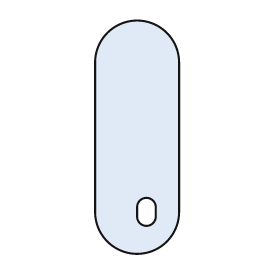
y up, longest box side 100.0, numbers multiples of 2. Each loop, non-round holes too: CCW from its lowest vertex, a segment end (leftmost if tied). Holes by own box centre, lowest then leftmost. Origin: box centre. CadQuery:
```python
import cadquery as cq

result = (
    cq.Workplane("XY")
    .moveTo(-18.0, -32.0)
    .threePointArc((0.0, -50.0), (18.0, -32.0))
    .lineTo(18.0, 32.0)
    .threePointArc((0.0, 50.0), (-18.0, 32.0))
    .close()
    .moveTo(0.0, -34.0)
    .threePointArc((4.0, -38.0), (8.0, -34.0))
    .lineTo(8.0, -30.0)
    .threePointArc((4.0, -26.0), (0.0, -30.0))
    .close()
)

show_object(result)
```